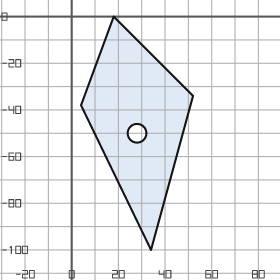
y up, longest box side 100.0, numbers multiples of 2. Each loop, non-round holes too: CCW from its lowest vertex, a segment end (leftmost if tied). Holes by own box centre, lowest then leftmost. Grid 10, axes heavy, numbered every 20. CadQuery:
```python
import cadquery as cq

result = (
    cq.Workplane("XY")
    .moveTo(34.0, -100.0)
    .lineTo(52.0, -34.0)
    .lineTo(18.0, 0.0)
    .lineTo(4.0, -38.0)
    .close()
    .moveTo(28.0, -50.0)
    .circle(4.0)
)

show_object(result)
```